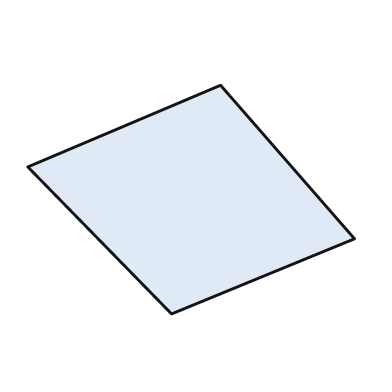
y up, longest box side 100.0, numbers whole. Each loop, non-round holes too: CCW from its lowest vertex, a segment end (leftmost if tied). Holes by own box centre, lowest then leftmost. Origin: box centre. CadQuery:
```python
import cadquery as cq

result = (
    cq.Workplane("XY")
    .moveTo(-6.0, -35.0)
    .lineTo(50.0, -12.0)
    .lineTo(9.0, 35.0)
    .lineTo(-50.0, 10.0)
    .close()
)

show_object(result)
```